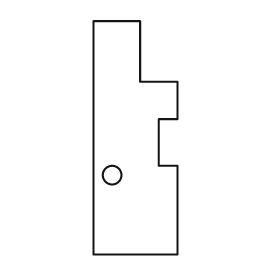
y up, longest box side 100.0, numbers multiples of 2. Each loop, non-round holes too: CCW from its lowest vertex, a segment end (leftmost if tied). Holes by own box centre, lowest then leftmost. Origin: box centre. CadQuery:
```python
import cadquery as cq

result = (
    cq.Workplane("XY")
    .moveTo(-18.0, -50.0)
    .lineTo(18.0, -50.0)
    .lineTo(18.0, -12.0)
    .lineTo(10.0, -12.0)
    .lineTo(10.0, 8.0)
    .lineTo(18.0, 8.0)
    .lineTo(18.0, 24.0)
    .lineTo(2.0, 24.0)
    .lineTo(2.0, 50.0)
    .lineTo(-18.0, 50.0)
    .close()
    .moveTo(-10.0, -16.0)
    .circle(4.0)
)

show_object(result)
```